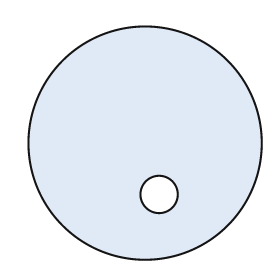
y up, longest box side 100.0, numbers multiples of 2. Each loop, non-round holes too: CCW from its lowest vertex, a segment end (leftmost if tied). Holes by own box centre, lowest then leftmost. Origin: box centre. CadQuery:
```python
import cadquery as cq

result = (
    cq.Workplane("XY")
    .moveTo(0.0, 0.0)
    .circle(50.0)
    .moveTo(6.0, -22.0)
    .circle(8.0)
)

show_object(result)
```